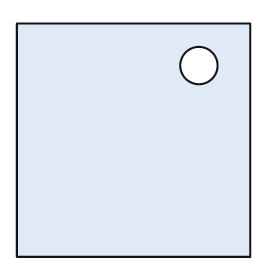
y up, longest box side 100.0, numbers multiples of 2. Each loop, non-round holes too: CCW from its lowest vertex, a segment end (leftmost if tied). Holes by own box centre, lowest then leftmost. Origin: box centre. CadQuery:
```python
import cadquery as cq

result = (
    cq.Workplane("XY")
    .moveTo(-50.0, -50.0)
    .lineTo(50.0, -50.0)
    .lineTo(50.0, 50.0)
    .lineTo(-50.0, 50.0)
    .close()
    .moveTo(28.0, 32.0)
    .circle(8.0)
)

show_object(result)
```